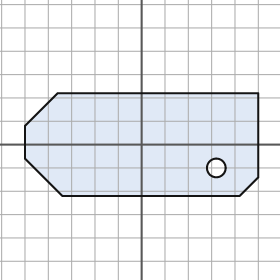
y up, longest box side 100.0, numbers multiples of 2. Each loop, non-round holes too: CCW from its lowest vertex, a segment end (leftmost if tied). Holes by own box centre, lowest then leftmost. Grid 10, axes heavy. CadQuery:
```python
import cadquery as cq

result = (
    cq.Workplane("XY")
    .moveTo(-34.0, -22.0)
    .lineTo(42.0, -22.0)
    .lineTo(50.0, -14.0)
    .lineTo(50.0, 22.0)
    .lineTo(-36.0, 22.0)
    .lineTo(-50.0, 8.0)
    .lineTo(-50.0, -6.0)
    .close()
    .moveTo(32.0, -10.0)
    .circle(4.0)
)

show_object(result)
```